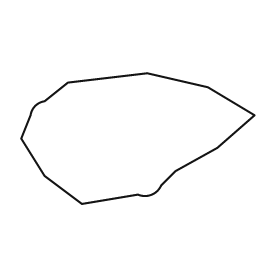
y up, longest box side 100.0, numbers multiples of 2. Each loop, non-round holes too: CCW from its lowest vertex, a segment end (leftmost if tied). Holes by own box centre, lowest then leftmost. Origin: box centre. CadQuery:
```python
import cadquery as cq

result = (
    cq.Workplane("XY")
    .moveTo(-24.0, -28.0)
    .lineTo(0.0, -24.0)
    .threePointArc((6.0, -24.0), (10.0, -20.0))
    .lineTo(16.0, -14.0)
    .lineTo(34.0, -4.0)
    .lineTo(50.0, 10.0)
    .lineTo(30.0, 22.0)
    .lineTo(4.0, 28.0)
    .lineTo(-30.0, 24.0)
    .lineTo(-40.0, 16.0)
    .threePointArc((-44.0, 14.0), (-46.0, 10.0))
    .lineTo(-50.0, 0.0)
    .lineTo(-40.0, -16.0)
    .close()
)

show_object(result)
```